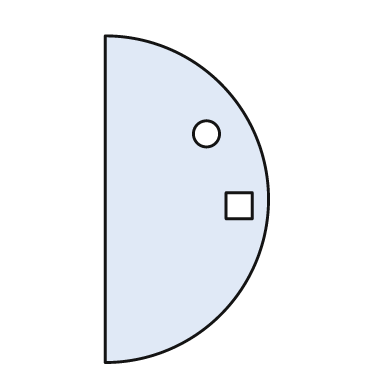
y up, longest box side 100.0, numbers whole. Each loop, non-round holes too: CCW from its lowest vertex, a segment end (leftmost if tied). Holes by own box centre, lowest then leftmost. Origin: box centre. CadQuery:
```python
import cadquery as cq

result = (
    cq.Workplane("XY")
    .moveTo(-25.0, -50.0)
    .threePointArc((25.0, 0.0), (-25.0, 50.0))
    .close()
    .moveTo(12.0, -6.0)
    .lineTo(20.0, -6.0)
    .lineTo(20.0, 2.0)
    .lineTo(12.0, 2.0)
    .close()
    .moveTo(6.0, 20.0)
    .circle(4.0)
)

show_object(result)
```